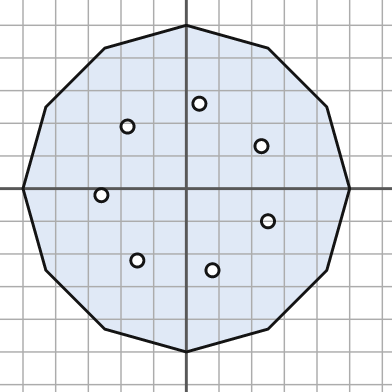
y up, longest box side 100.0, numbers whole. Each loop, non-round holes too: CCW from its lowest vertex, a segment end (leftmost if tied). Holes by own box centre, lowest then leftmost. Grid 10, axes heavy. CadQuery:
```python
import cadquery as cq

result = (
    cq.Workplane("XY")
    .moveTo(0.0, -50.0)
    .lineTo(25.0, -43.0)
    .lineTo(43.0, -25.0)
    .lineTo(50.0, 0.0)
    .lineTo(43.0, 25.0)
    .lineTo(25.0, 43.0)
    .lineTo(0.0, 50.0)
    .lineTo(-25.0, 43.0)
    .lineTo(-43.0, 25.0)
    .lineTo(-50.0, 0.0)
    .lineTo(-43.0, -25.0)
    .lineTo(-25.0, -43.0)
    .close()
    .moveTo(8.0, -25.0)
    .circle(2.0)
    .moveTo(-15.0, -22.0)
    .circle(2.0)
    .moveTo(25.0, -10.0)
    .circle(2.0)
    .moveTo(-26.0, -2.0)
    .circle(2.0)
    .moveTo(23.0, 13.0)
    .circle(2.0)
    .moveTo(-18.0, 19.0)
    .circle(2.0)
    .moveTo(4.0, 26.0)
    .circle(2.0)
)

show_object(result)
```